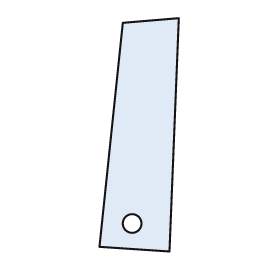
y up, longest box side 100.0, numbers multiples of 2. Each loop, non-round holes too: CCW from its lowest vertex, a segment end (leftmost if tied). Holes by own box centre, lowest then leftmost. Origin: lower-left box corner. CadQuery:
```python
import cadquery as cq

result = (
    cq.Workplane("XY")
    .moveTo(30.0, 0.0)
    .lineTo(34.0, 100.0)
    .lineTo(10.0, 98.0)
    .lineTo(0.0, 2.0)
    .close()
    .moveTo(14.0, 12.0)
    .circle(4.0)
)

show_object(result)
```